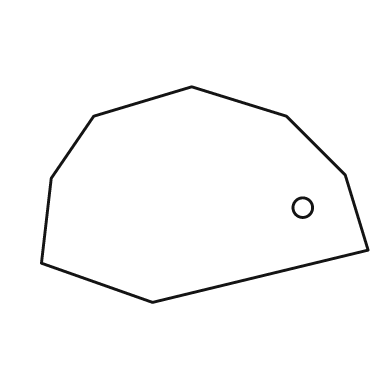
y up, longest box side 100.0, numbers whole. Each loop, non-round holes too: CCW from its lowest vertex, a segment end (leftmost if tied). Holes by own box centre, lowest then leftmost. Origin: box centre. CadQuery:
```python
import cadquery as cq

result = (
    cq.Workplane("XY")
    .moveTo(-16.0, -33.0)
    .lineTo(50.0, -17.0)
    .lineTo(43.0, 6.0)
    .lineTo(25.0, 24.0)
    .lineTo(-4.0, 33.0)
    .lineTo(-34.0, 24.0)
    .lineTo(-47.0, 5.0)
    .lineTo(-50.0, -21.0)
    .close()
    .moveTo(30.0, -4.0)
    .circle(3.0)
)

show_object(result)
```